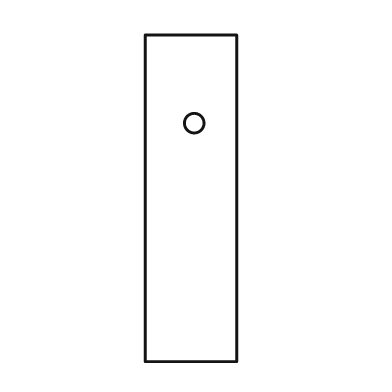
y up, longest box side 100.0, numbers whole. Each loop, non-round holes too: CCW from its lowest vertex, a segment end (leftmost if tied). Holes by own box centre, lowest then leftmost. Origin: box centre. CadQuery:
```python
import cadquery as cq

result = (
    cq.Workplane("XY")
    .moveTo(-14.0, -50.0)
    .lineTo(14.0, -50.0)
    .lineTo(14.0, 50.0)
    .lineTo(-14.0, 50.0)
    .close()
    .moveTo(1.0, 23.0)
    .circle(3.0)
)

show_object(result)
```